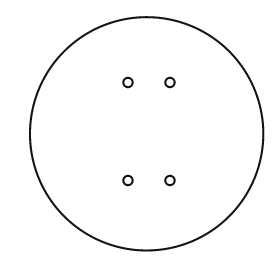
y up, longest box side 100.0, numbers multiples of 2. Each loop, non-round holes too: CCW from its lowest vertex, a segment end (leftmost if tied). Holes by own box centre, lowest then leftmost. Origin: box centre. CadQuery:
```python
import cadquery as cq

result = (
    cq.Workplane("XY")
    .moveTo(0.0, 0.0)
    .circle(50.0)
    .moveTo(-8.0, -20.0)
    .circle(2.0)
    .moveTo(10.0, -20.0)
    .circle(2.0)
    .moveTo(-8.0, 22.0)
    .circle(2.0)
    .moveTo(10.0, 22.0)
    .circle(2.0)
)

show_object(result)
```